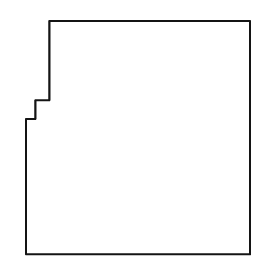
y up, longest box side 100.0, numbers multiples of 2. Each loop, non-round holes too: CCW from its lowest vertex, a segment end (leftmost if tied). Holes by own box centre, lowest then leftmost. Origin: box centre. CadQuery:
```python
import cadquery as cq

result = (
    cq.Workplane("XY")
    .moveTo(-48.0, -50.0)
    .lineTo(48.0, -50.0)
    .lineTo(48.0, 50.0)
    .lineTo(-38.0, 50.0)
    .lineTo(-38.0, 16.0)
    .lineTo(-44.0, 16.0)
    .lineTo(-44.0, 8.0)
    .lineTo(-48.0, 8.0)
    .close()
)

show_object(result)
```